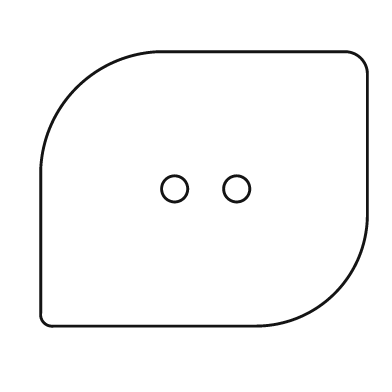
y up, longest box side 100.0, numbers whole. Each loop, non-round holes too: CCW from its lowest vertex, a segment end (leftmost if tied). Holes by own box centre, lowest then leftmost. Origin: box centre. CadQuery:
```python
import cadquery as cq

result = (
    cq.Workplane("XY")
    .moveTo(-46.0, -42.0)
    .lineTo(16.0, -42.0)
    .threePointArc((40.0, -32.0), (50.0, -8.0))
    .lineTo(50.0, 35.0)
    .threePointArc((48.0, 40.0), (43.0, 42.0))
    .lineTo(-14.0, 42.0)
    .threePointArc((-39.0, 31.0), (-50.0, 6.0))
    .lineTo(-50.0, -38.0)
    .threePointArc((-49.0, -41.0), (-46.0, -42.0))
    .close()
    .moveTo(-9.0, 0.0)
    .circle(4.0)
    .moveTo(10.0, 0.0)
    .circle(4.0)
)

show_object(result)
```